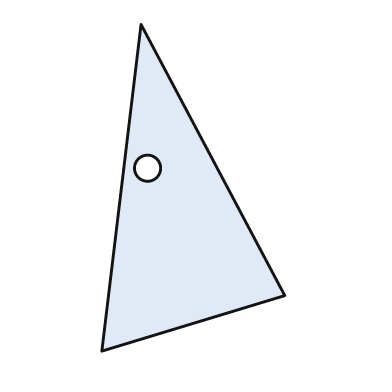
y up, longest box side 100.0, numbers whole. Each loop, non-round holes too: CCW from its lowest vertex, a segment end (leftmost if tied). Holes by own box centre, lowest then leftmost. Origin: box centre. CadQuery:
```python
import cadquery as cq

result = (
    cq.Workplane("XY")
    .moveTo(-28.0, -50.0)
    .lineTo(28.0, -33.0)
    .lineTo(-16.0, 50.0)
    .close()
    .moveTo(-14.0, 6.0)
    .circle(4.0)
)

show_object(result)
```